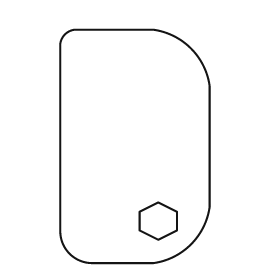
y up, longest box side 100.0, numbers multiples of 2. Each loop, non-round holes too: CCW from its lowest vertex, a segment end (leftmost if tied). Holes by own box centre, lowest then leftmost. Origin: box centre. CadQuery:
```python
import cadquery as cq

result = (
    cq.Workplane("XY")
    .moveTo(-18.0, -50.0)
    .lineTo(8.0, -50.0)
    .threePointArc((24.0, -42.0), (32.0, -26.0))
    .lineTo(32.0, 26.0)
    .threePointArc((24.0, 42.0), (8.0, 50.0))
    .lineTo(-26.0, 50.0)
    .threePointArc((-30.0, 48.0), (-32.0, 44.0))
    .lineTo(-32.0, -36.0)
    .threePointArc((-28.0, -46.0), (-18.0, -50.0))
    .close()
    .moveTo(10.0, -40.0)
    .lineTo(18.0, -36.0)
    .lineTo(18.0, -28.0)
    .lineTo(10.0, -24.0)
    .lineTo(2.0, -28.0)
    .lineTo(2.0, -36.0)
    .close()
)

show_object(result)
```